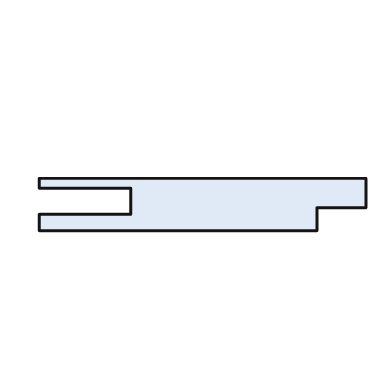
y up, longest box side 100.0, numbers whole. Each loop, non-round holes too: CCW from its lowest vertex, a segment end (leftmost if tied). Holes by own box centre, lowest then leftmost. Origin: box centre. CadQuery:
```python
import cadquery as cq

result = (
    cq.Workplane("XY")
    .moveTo(-50.0, -8.0)
    .lineTo(35.0, -8.0)
    .lineTo(35.0, -1.0)
    .lineTo(50.0, -1.0)
    .lineTo(50.0, 8.0)
    .lineTo(-50.0, 8.0)
    .lineTo(-50.0, 5.0)
    .lineTo(-22.0, 5.0)
    .lineTo(-22.0, -3.0)
    .lineTo(-50.0, -3.0)
    .close()
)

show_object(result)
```